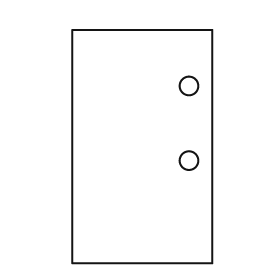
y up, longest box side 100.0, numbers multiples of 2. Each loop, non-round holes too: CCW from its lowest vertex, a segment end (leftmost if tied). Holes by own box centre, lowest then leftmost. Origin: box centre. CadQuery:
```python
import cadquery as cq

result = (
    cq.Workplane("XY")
    .moveTo(-30.0, -50.0)
    .lineTo(30.0, -50.0)
    .lineTo(30.0, 50.0)
    .lineTo(-30.0, 50.0)
    .close()
    .moveTo(20.0, -6.0)
    .circle(4.0)
    .moveTo(20.0, 26.0)
    .circle(4.0)
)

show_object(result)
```